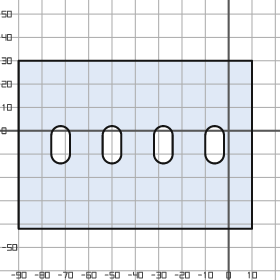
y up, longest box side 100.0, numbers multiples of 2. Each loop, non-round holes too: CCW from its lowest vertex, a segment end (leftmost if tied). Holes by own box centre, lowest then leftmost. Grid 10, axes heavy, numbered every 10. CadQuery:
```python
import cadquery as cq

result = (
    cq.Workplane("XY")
    .moveTo(-90.0, -42.0)
    .lineTo(10.0, -42.0)
    .lineTo(10.0, 30.0)
    .lineTo(-90.0, 30.0)
    .close()
    .moveTo(-76.0, -10.0)
    .threePointArc((-72.0, -14.0), (-68.0, -10.0))
    .lineTo(-68.0, -2.0)
    .threePointArc((-72.0, 2.0), (-76.0, -2.0))
    .close()
    .moveTo(-54.0, -10.0)
    .threePointArc((-50.0, -14.0), (-46.0, -10.0))
    .lineTo(-46.0, -2.0)
    .threePointArc((-50.0, 2.0), (-54.0, -2.0))
    .close()
    .moveTo(-32.0, -10.0)
    .threePointArc((-28.0, -14.0), (-24.0, -10.0))
    .lineTo(-24.0, -2.0)
    .threePointArc((-28.0, 2.0), (-32.0, -2.0))
    .close()
    .moveTo(-10.0, -10.0)
    .threePointArc((-6.0, -14.0), (-2.0, -10.0))
    .lineTo(-2.0, -2.0)
    .threePointArc((-6.0, 2.0), (-10.0, -2.0))
    .close()
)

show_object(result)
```